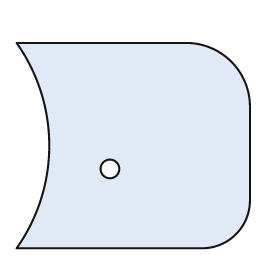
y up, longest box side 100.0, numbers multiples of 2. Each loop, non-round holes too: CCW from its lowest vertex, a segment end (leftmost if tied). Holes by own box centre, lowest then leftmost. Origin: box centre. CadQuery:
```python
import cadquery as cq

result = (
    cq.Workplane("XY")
    .moveTo(-50.0, -44.0)
    .lineTo(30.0, -44.0)
    .threePointArc((44.0, -38.0), (50.0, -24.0))
    .lineTo(50.0, 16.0)
    .threePointArc((42.0, 36.0), (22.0, 44.0))
    .lineTo(-50.0, 44.0)
    .threePointArc((-36.0, 0.0), (-50.0, -44.0))
    .close()
    .moveTo(-10.0, -10.0)
    .circle(4.0)
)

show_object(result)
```